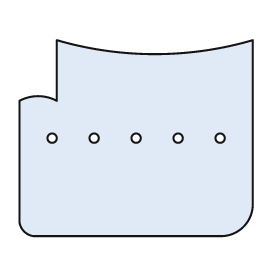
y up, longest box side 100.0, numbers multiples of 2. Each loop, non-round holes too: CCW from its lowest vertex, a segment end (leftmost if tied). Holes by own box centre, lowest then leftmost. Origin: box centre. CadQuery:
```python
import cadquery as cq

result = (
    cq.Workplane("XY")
    .moveTo(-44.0, -42.0)
    .lineTo(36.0, -42.0)
    .threePointArc((46.0, -38.0), (50.0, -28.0))
    .lineTo(50.0, 42.0)
    .threePointArc((8.0, 36.0), (-34.0, 42.0))
    .lineTo(-34.0, 16.0)
    .threePointArc((-42.0, 18.0), (-50.0, 16.0))
    .lineTo(-50.0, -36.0)
    .threePointArc((-48.0, -40.0), (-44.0, -42.0))
    .close()
    .moveTo(-36.0, 0.0)
    .circle(2.0)
    .moveTo(-18.0, 0.0)
    .circle(2.0)
    .moveTo(0.0, 0.0)
    .circle(2.0)
    .moveTo(18.0, 0.0)
    .circle(2.0)
    .moveTo(36.0, 0.0)
    .circle(2.0)
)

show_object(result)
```